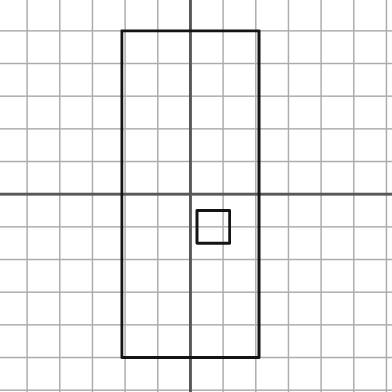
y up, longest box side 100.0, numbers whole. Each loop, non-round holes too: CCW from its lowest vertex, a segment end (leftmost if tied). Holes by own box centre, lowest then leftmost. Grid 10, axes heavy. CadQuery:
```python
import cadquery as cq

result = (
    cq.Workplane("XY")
    .moveTo(-21.0, -50.0)
    .lineTo(21.0, -50.0)
    .lineTo(21.0, 50.0)
    .lineTo(-21.0, 50.0)
    .close()
    .moveTo(2.0, -15.0)
    .lineTo(12.0, -15.0)
    .lineTo(12.0, -5.0)
    .lineTo(2.0, -5.0)
    .close()
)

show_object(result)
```